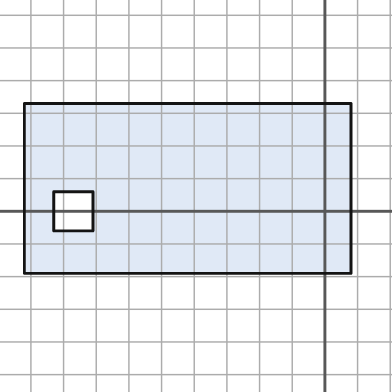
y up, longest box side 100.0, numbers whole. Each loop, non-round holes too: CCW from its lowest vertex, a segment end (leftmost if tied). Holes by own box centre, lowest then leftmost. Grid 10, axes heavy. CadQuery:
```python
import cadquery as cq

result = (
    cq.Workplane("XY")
    .moveTo(-92.0, -19.0)
    .lineTo(8.0, -19.0)
    .lineTo(8.0, 33.0)
    .lineTo(-92.0, 33.0)
    .close()
    .moveTo(-83.0, -6.0)
    .lineTo(-71.0, -6.0)
    .lineTo(-71.0, 6.0)
    .lineTo(-83.0, 6.0)
    .close()
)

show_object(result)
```